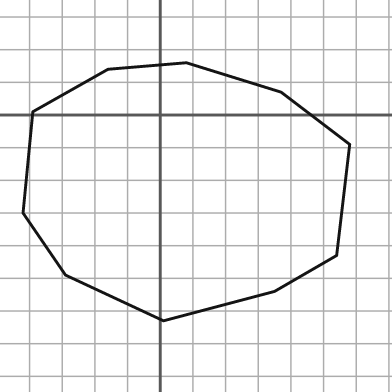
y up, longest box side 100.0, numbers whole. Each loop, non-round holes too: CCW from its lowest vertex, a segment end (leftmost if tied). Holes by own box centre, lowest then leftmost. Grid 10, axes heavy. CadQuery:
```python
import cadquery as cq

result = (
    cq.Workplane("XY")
    .moveTo(1.0, -63.0)
    .lineTo(35.0, -54.0)
    .lineTo(54.0, -43.0)
    .lineTo(58.0, -9.0)
    .lineTo(37.0, 7.0)
    .lineTo(8.0, 16.0)
    .lineTo(-16.0, 14.0)
    .lineTo(-39.0, 1.0)
    .lineTo(-42.0, -30.0)
    .lineTo(-29.0, -49.0)
    .close()
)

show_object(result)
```